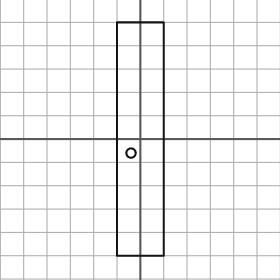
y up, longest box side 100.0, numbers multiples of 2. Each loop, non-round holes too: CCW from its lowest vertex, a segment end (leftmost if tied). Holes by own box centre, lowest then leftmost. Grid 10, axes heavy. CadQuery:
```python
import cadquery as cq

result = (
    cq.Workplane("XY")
    .moveTo(-10.0, -50.0)
    .lineTo(10.0, -50.0)
    .lineTo(10.0, 50.0)
    .lineTo(-10.0, 50.0)
    .close()
    .moveTo(-4.0, -6.0)
    .circle(2.0)
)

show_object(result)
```